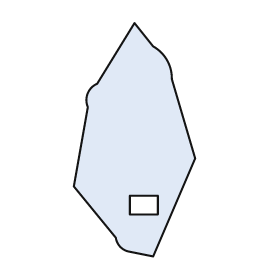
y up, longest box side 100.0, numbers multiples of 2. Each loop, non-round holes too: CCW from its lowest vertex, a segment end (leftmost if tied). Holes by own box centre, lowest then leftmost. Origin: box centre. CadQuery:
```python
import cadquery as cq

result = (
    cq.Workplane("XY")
    .moveTo(8.0, -50.0)
    .lineTo(26.0, -8.0)
    .lineTo(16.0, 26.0)
    .threePointArc((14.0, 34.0), (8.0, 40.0))
    .lineTo(0.0, 50.0)
    .lineTo(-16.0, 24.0)
    .threePointArc((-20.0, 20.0), (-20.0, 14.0))
    .lineTo(-26.0, -20.0)
    .lineTo(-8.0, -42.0)
    .threePointArc((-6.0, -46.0), (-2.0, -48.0))
    .close()
    .moveTo(-2.0, -32.0)
    .lineTo(10.0, -32.0)
    .lineTo(10.0, -24.0)
    .lineTo(-2.0, -24.0)
    .close()
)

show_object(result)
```